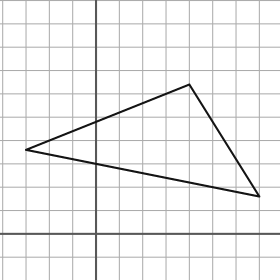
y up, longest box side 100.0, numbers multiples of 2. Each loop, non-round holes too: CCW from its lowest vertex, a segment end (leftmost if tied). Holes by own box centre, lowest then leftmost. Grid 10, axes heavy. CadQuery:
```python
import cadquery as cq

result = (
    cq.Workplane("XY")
    .moveTo(70.0, 16.0)
    .lineTo(40.0, 64.0)
    .lineTo(-30.0, 36.0)
    .close()
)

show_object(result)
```